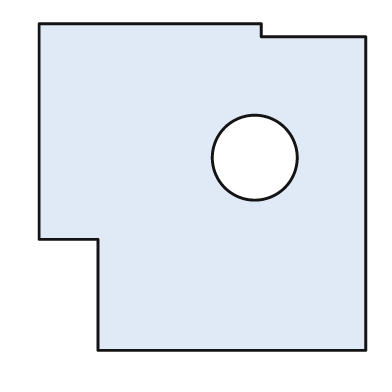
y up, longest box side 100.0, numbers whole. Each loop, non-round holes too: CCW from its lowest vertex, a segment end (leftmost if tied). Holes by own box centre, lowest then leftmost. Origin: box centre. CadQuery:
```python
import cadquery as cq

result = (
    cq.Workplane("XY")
    .moveTo(-32.0, -50.0)
    .lineTo(50.0, -50.0)
    .lineTo(50.0, 46.0)
    .lineTo(18.0, 46.0)
    .lineTo(18.0, 50.0)
    .lineTo(-50.0, 50.0)
    .lineTo(-50.0, -16.0)
    .lineTo(-32.0, -16.0)
    .close()
    .moveTo(16.0, 9.0)
    .circle(13.0)
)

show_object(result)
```